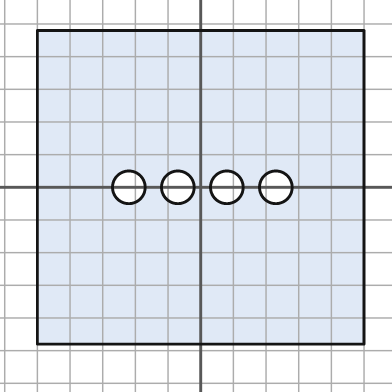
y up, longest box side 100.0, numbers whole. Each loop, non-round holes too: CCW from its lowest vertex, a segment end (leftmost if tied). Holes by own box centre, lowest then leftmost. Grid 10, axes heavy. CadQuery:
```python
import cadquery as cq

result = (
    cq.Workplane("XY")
    .moveTo(-50.0, -48.0)
    .lineTo(50.0, -48.0)
    .lineTo(50.0, 48.0)
    .lineTo(-50.0, 48.0)
    .close()
    .moveTo(-22.0, 0.0)
    .circle(5.0)
    .moveTo(-7.0, 0.0)
    .circle(5.0)
    .moveTo(8.0, 0.0)
    .circle(5.0)
    .moveTo(23.0, 0.0)
    .circle(5.0)
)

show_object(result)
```